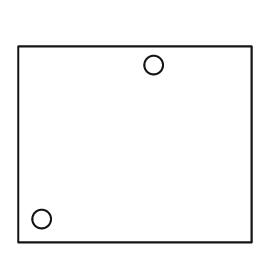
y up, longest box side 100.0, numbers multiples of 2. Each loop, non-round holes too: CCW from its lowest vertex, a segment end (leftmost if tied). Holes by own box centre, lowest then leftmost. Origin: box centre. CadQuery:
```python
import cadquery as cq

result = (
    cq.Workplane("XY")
    .moveTo(-50.0, -42.0)
    .lineTo(50.0, -42.0)
    .lineTo(50.0, 42.0)
    .lineTo(-50.0, 42.0)
    .close()
    .moveTo(-40.0, -32.0)
    .circle(4.0)
    .moveTo(8.0, 34.0)
    .circle(4.0)
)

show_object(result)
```